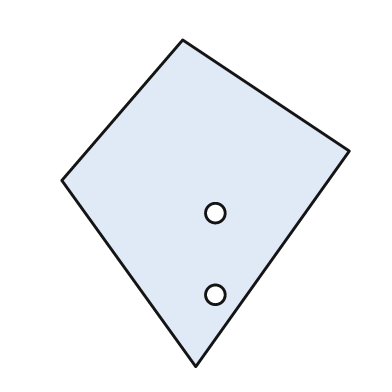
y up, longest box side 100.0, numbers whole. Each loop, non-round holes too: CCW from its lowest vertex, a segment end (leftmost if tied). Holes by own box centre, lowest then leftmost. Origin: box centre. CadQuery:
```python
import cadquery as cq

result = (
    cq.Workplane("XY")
    .moveTo(-3.0, -50.0)
    .lineTo(44.0, 16.0)
    .lineTo(-7.0, 50.0)
    .lineTo(-44.0, 7.0)
    .close()
    .moveTo(3.0, -28.0)
    .circle(3.0)
    .moveTo(3.0, -3.0)
    .circle(3.0)
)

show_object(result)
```